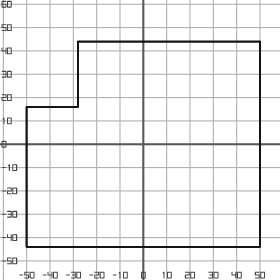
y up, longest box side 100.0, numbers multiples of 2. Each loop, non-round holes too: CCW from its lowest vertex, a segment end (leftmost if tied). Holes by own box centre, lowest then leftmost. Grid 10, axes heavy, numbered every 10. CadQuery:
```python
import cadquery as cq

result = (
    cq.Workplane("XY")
    .moveTo(-50.0, -44.0)
    .lineTo(50.0, -44.0)
    .lineTo(50.0, 44.0)
    .lineTo(-28.0, 44.0)
    .lineTo(-28.0, 16.0)
    .lineTo(-50.0, 16.0)
    .close()
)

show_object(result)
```